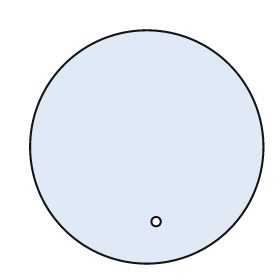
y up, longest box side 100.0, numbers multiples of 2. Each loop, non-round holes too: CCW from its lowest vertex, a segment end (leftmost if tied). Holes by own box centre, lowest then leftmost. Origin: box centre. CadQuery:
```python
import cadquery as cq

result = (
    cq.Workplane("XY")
    .moveTo(0.0, 0.0)
    .circle(50.0)
    .moveTo(4.0, -32.0)
    .circle(2.0)
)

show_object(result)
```